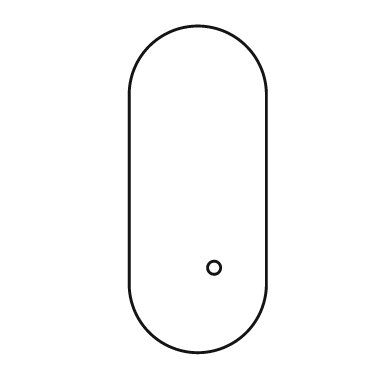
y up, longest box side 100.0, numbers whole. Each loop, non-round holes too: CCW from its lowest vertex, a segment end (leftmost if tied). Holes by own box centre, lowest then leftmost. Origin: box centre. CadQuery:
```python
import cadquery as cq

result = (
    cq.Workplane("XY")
    .moveTo(-21.0, -29.0)
    .threePointArc((0.0, -50.0), (21.0, -29.0))
    .lineTo(21.0, 29.0)
    .threePointArc((0.0, 50.0), (-21.0, 29.0))
    .close()
    .moveTo(5.0, -24.0)
    .circle(2.0)
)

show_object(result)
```